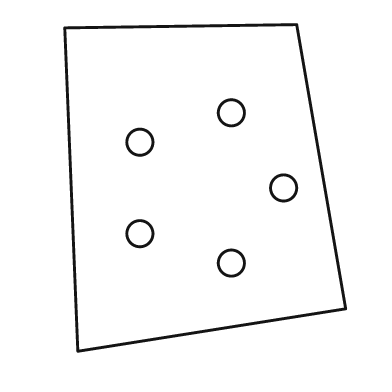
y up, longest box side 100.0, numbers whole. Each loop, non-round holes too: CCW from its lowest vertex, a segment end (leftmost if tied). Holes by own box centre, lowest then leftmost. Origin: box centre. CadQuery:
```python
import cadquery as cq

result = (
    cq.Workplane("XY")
    .moveTo(-39.0, -50.0)
    .lineTo(43.0, -37.0)
    .lineTo(28.0, 50.0)
    .lineTo(-43.0, 49.0)
    .close()
    .moveTo(8.0, -23.0)
    .circle(4.0)
    .moveTo(-20.0, -14.0)
    .circle(4.0)
    .moveTo(24.0, 0.0)
    .circle(4.0)
    .moveTo(-20.0, 14.0)
    .circle(4.0)
    .moveTo(8.0, 23.0)
    .circle(4.0)
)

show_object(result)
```